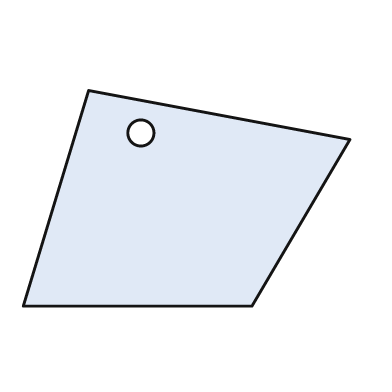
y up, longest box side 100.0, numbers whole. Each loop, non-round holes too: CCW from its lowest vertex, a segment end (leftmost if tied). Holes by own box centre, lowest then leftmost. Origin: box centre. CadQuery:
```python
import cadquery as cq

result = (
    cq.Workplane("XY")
    .moveTo(-50.0, -33.0)
    .lineTo(20.0, -33.0)
    .lineTo(50.0, 18.0)
    .lineTo(-30.0, 33.0)
    .close()
    .moveTo(-14.0, 20.0)
    .circle(4.0)
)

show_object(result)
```